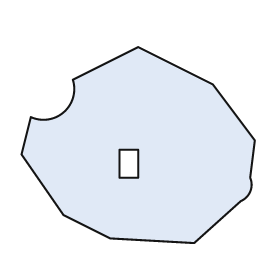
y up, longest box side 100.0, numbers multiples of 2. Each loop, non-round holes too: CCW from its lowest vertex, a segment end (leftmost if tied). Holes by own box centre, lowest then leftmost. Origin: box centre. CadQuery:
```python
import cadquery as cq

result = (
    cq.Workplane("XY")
    .moveTo(24.0, -42.0)
    .lineTo(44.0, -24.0)
    .threePointArc((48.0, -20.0), (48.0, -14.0))
    .lineTo(50.0, 2.0)
    .lineTo(32.0, 26.0)
    .lineTo(0.0, 42.0)
    .lineTo(-28.0, 28.0)
    .threePointArc((-32.0, 14.0), (-46.0, 12.0))
    .lineTo(-50.0, -4.0)
    .lineTo(-32.0, -30.0)
    .lineTo(-12.0, -40.0)
    .close()
    .moveTo(-8.0, -14.0)
    .lineTo(0.0, -14.0)
    .lineTo(0.0, -2.0)
    .lineTo(-8.0, -2.0)
    .close()
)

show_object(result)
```